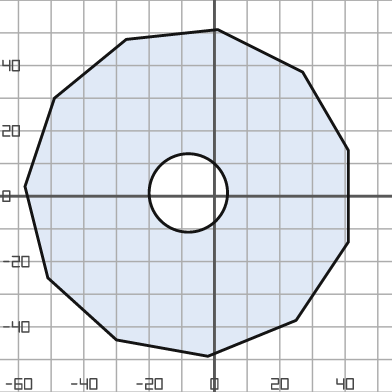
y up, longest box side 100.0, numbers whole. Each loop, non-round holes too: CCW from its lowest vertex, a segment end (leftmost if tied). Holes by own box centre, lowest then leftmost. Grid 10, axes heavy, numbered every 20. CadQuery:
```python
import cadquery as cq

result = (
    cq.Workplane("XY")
    .moveTo(-2.0, -49.0)
    .lineTo(25.0, -38.0)
    .lineTo(41.0, -14.0)
    .lineTo(41.0, 14.0)
    .lineTo(27.0, 38.0)
    .lineTo(1.0, 51.0)
    .lineTo(-27.0, 48.0)
    .lineTo(-49.0, 30.0)
    .lineTo(-58.0, 3.0)
    .lineTo(-51.0, -25.0)
    .lineTo(-30.0, -44.0)
    .close()
    .moveTo(-8.0, 1.0)
    .circle(12.0)
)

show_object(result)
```